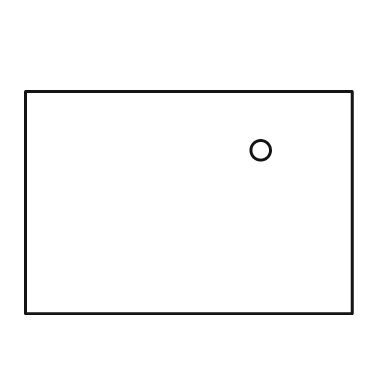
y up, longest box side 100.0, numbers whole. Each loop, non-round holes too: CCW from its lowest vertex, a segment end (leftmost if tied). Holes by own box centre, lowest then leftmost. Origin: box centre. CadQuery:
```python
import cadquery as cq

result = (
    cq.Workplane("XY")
    .moveTo(-50.0, -34.0)
    .lineTo(50.0, -34.0)
    .lineTo(50.0, 34.0)
    .lineTo(-50.0, 34.0)
    .close()
    .moveTo(22.0, 16.0)
    .circle(3.0)
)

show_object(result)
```